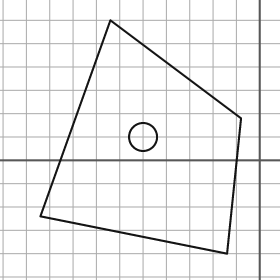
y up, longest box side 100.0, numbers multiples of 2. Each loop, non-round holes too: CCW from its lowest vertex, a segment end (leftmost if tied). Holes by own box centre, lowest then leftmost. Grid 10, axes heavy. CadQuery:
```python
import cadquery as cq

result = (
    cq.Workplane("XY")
    .moveTo(-14.0, -40.0)
    .lineTo(-8.0, 18.0)
    .lineTo(-64.0, 60.0)
    .lineTo(-94.0, -24.0)
    .close()
    .moveTo(-50.0, 10.0)
    .circle(6.0)
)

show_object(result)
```